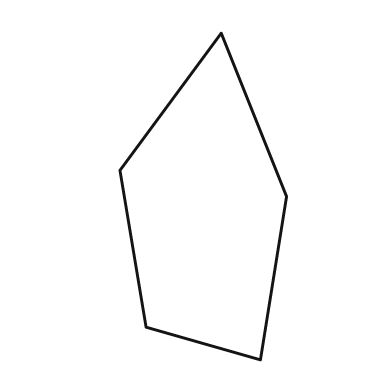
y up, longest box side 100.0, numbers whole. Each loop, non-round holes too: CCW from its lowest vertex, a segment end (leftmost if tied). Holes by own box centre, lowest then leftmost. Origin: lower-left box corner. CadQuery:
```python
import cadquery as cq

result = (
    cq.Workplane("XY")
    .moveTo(43.0, 0.0)
    .lineTo(51.0, 50.0)
    .lineTo(31.0, 100.0)
    .lineTo(0.0, 58.0)
    .lineTo(8.0, 10.0)
    .close()
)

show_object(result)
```